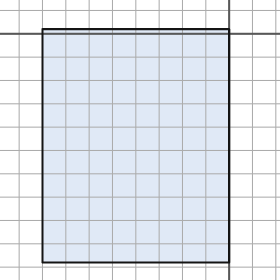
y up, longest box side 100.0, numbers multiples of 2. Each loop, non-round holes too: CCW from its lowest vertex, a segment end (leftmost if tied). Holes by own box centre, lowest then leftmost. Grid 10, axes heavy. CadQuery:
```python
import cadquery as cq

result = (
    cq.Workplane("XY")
    .moveTo(-80.0, -98.0)
    .lineTo(0.0, -98.0)
    .lineTo(0.0, 2.0)
    .lineTo(-80.0, 2.0)
    .close()
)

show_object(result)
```